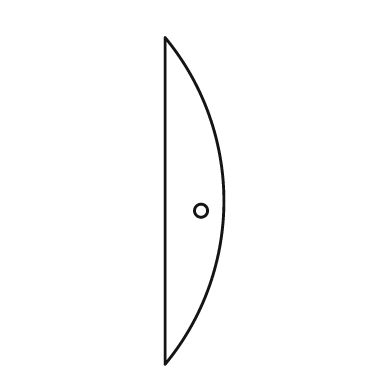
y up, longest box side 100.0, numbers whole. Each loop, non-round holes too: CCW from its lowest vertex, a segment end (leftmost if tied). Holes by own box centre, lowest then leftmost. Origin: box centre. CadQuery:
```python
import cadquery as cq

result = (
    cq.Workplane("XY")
    .moveTo(-9.0, -50.0)
    .threePointArc((9.0, 0.0), (-9.0, 50.0))
    .close()
    .moveTo(2.0, -3.0)
    .circle(2.0)
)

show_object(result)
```